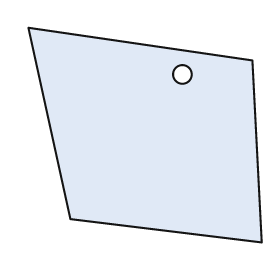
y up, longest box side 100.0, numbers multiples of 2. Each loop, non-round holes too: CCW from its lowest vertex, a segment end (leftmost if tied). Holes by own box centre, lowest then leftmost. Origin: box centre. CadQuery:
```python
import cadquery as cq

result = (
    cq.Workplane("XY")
    .moveTo(50.0, -46.0)
    .lineTo(46.0, 32.0)
    .lineTo(-50.0, 46.0)
    .lineTo(-32.0, -36.0)
    .close()
    .moveTo(16.0, 26.0)
    .circle(4.0)
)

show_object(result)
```